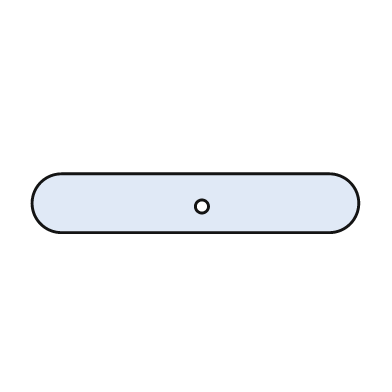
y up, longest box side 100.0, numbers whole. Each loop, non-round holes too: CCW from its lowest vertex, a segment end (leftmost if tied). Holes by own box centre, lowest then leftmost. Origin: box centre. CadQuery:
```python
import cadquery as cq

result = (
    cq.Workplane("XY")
    .moveTo(-41.0, -9.0)
    .lineTo(41.0, -9.0)
    .threePointArc((50.0, 0.0), (41.0, 9.0))
    .lineTo(-41.0, 9.0)
    .threePointArc((-50.0, 0.0), (-41.0, -9.0))
    .close()
    .moveTo(2.0, -1.0)
    .circle(2.0)
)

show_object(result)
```